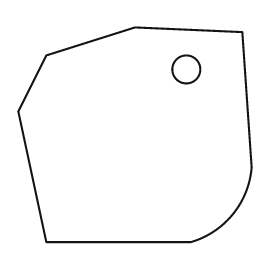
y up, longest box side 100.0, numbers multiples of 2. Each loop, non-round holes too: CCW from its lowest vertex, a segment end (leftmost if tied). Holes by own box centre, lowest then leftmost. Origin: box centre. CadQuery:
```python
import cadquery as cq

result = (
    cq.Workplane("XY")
    .moveTo(-38.0, -46.0)
    .lineTo(24.0, -46.0)
    .threePointArc((42.0, -34.0), (50.0, -14.0))
    .lineTo(46.0, 44.0)
    .lineTo(0.0, 46.0)
    .lineTo(-38.0, 34.0)
    .lineTo(-50.0, 10.0)
    .close()
    .moveTo(22.0, 28.0)
    .circle(6.0)
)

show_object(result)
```